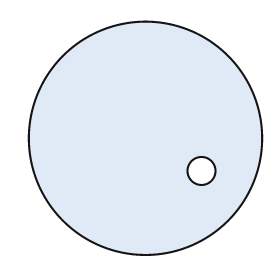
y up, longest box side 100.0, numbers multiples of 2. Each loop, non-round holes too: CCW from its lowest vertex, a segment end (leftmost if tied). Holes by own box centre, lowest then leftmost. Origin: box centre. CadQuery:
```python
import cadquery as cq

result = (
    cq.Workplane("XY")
    .moveTo(0.0, 0.0)
    .circle(50.0)
    .moveTo(24.0, -14.0)
    .circle(6.0)
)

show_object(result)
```